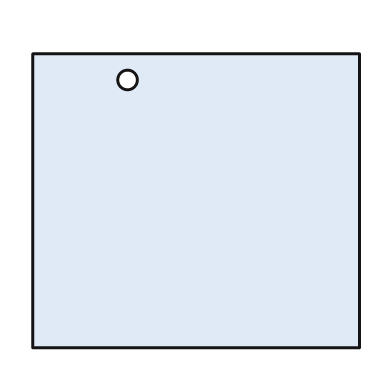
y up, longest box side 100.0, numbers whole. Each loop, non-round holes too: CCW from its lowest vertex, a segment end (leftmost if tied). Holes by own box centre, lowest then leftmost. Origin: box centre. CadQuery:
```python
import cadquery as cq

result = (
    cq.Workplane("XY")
    .moveTo(-50.0, -45.0)
    .lineTo(50.0, -45.0)
    .lineTo(50.0, 45.0)
    .lineTo(-50.0, 45.0)
    .close()
    .moveTo(-21.0, 37.0)
    .circle(3.0)
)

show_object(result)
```